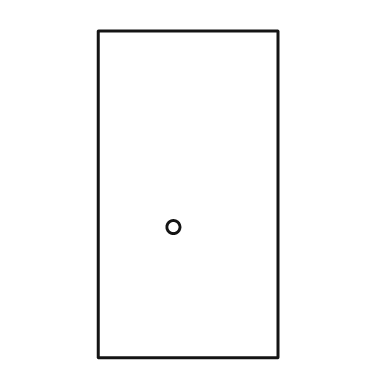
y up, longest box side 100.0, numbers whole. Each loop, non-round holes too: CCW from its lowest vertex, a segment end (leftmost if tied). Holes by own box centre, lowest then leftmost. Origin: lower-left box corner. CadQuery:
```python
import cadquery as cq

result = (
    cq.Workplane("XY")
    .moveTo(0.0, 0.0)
    .lineTo(55.0, 0.0)
    .lineTo(55.0, 100.0)
    .lineTo(0.0, 100.0)
    .close()
    .moveTo(23.0, 40.0)
    .circle(2.0)
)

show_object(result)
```